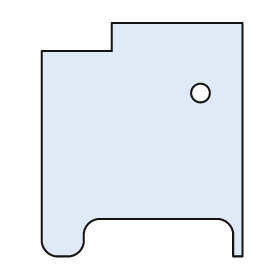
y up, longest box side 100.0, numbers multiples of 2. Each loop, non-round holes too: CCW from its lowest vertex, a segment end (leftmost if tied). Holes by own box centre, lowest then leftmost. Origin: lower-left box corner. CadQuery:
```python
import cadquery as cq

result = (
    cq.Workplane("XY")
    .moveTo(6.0, 0.0)
    .lineTo(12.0, 0.0)
    .threePointArc((16.0, 2.0), (18.0, 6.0))
    .lineTo(18.0, 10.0)
    .threePointArc((20.0, 14.0), (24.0, 16.0))
    .lineTo(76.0, 16.0)
    .threePointArc((80.0, 14.0), (82.0, 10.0))
    .lineTo(82.0, 0.0)
    .lineTo(86.0, 0.0)
    .lineTo(86.0, 100.0)
    .lineTo(30.0, 100.0)
    .lineTo(30.0, 88.0)
    .lineTo(0.0, 88.0)
    .lineTo(0.0, 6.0)
    .threePointArc((2.0, 2.0), (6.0, 0.0))
    .close()
    .moveTo(68.0, 70.0)
    .circle(4.0)
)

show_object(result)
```